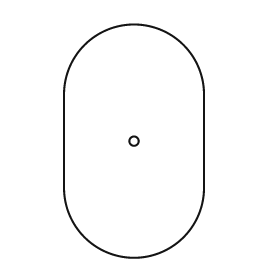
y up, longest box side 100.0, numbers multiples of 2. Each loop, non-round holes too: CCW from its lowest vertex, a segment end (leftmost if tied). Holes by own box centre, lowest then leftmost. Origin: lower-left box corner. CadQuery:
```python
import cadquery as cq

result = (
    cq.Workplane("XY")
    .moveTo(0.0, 30.0)
    .threePointArc((30.0, 0.0), (60.0, 30.0))
    .lineTo(60.0, 70.0)
    .threePointArc((30.0, 100.0), (0.0, 70.0))
    .close()
    .moveTo(30.0, 50.0)
    .circle(2.0)
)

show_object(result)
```